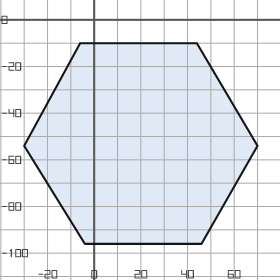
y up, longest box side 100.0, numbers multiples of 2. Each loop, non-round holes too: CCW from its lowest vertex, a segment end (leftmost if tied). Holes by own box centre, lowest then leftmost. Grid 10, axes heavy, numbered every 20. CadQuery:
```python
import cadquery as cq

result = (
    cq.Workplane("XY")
    .moveTo(-4.0, -96.0)
    .lineTo(46.0, -96.0)
    .lineTo(70.0, -54.0)
    .lineTo(44.0, -10.0)
    .lineTo(-6.0, -10.0)
    .lineTo(-30.0, -54.0)
    .close()
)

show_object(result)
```